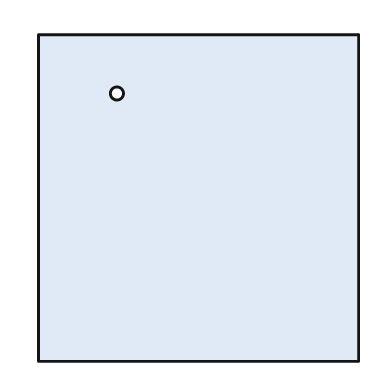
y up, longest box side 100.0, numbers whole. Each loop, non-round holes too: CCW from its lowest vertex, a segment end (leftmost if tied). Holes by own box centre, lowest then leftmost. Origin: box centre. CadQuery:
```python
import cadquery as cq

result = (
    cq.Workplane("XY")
    .moveTo(-49.0, -50.0)
    .lineTo(49.0, -50.0)
    .lineTo(49.0, 50.0)
    .lineTo(-49.0, 50.0)
    .close()
    .moveTo(-25.0, 32.0)
    .circle(2.0)
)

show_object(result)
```